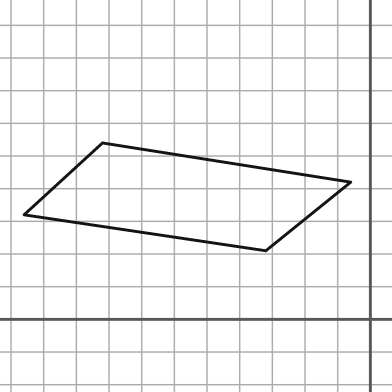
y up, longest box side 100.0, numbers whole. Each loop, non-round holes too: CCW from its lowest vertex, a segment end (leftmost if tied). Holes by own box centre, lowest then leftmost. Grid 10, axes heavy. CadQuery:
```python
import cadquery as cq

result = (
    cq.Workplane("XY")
    .moveTo(-32.0, 21.0)
    .lineTo(-6.0, 42.0)
    .lineTo(-82.0, 54.0)
    .lineTo(-106.0, 32.0)
    .close()
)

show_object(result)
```